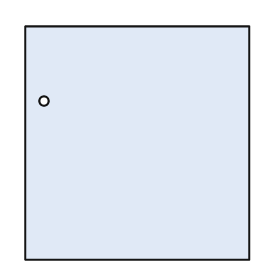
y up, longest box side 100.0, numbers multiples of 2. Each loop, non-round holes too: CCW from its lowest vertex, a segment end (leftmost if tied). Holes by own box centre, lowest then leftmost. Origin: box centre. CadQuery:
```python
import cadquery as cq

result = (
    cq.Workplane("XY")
    .moveTo(-48.0, -50.0)
    .lineTo(48.0, -50.0)
    .lineTo(48.0, 50.0)
    .lineTo(-48.0, 50.0)
    .close()
    .moveTo(-40.0, 18.0)
    .circle(2.0)
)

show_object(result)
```